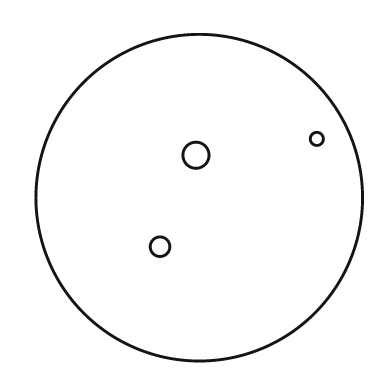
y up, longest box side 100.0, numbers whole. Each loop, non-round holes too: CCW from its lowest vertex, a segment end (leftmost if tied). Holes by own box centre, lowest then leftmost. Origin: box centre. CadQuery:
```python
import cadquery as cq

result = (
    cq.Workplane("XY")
    .moveTo(0.0, 0.0)
    .circle(50.0)
    .moveTo(-12.0, -15.0)
    .circle(3.0)
    .moveTo(-1.0, 13.0)
    .circle(4.0)
    .moveTo(36.0, 18.0)
    .circle(2.0)
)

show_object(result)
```